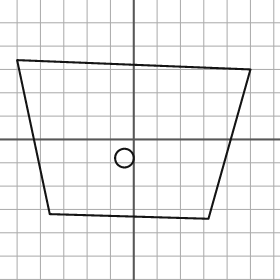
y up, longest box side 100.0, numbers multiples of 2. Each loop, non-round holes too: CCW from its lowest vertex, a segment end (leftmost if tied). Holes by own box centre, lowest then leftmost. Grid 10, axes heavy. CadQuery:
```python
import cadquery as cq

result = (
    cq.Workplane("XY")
    .moveTo(32.0, -34.0)
    .lineTo(50.0, 30.0)
    .lineTo(-50.0, 34.0)
    .lineTo(-36.0, -32.0)
    .close()
    .moveTo(-4.0, -8.0)
    .circle(4.0)
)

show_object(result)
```